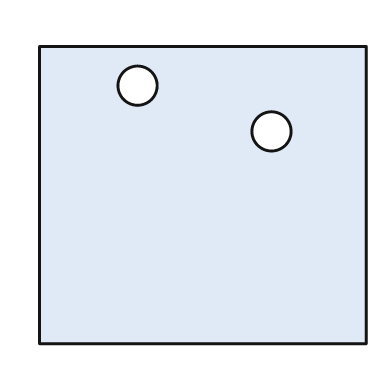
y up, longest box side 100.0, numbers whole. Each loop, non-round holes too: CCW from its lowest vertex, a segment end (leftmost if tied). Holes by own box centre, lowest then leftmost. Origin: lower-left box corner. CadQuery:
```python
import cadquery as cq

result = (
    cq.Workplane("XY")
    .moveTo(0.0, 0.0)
    .lineTo(100.0, 0.0)
    .lineTo(100.0, 91.0)
    .lineTo(0.0, 91.0)
    .close()
    .moveTo(71.0, 65.0)
    .circle(6.0)
    .moveTo(30.0, 79.0)
    .circle(6.0)
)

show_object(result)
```